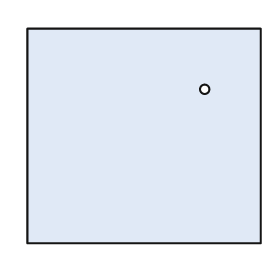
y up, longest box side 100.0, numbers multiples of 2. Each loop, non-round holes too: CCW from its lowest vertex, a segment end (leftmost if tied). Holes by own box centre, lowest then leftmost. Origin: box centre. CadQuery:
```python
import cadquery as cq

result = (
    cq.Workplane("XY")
    .moveTo(-50.0, -46.0)
    .lineTo(50.0, -46.0)
    .lineTo(50.0, 46.0)
    .lineTo(-50.0, 46.0)
    .close()
    .moveTo(26.0, 20.0)
    .circle(2.0)
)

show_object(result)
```